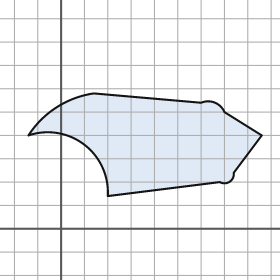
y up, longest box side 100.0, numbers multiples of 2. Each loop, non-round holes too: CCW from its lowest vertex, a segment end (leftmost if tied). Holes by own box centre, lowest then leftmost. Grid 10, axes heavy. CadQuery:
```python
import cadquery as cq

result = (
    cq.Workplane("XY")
    .moveTo(20.0, 14.0)
    .lineTo(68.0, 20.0)
    .threePointArc((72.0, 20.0), (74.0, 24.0))
    .lineTo(86.0, 40.0)
    .lineTo(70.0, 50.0)
    .threePointArc((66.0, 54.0), (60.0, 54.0))
    .lineTo(14.0, 58.0)
    .threePointArc((-2.0, 52.0), (-14.0, 40.0))
    .threePointArc((10.0, 36.0), (20.0, 14.0))
    .close()
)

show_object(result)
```